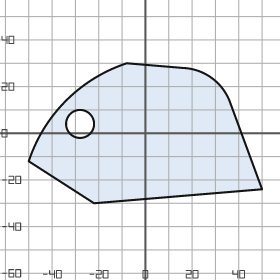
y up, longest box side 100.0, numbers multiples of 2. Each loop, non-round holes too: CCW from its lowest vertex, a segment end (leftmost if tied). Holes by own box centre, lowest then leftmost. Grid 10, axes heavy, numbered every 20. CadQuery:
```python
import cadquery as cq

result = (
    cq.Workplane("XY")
    .moveTo(-22.0, -30.0)
    .lineTo(50.0, -24.0)
    .lineTo(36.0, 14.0)
    .threePointArc((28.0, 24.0), (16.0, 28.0))
    .lineTo(-8.0, 30.0)
    .threePointArc((-34.0, 14.0), (-50.0, -12.0))
    .close()
    .moveTo(-28.0, 4.0)
    .circle(6.0)
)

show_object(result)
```